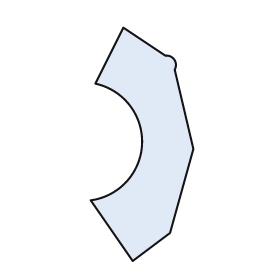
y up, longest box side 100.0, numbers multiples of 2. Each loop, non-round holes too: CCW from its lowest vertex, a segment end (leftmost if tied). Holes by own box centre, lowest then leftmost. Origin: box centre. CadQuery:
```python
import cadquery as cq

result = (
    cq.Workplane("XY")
    .moveTo(-4.0, -50.0)
    .lineTo(12.0, -38.0)
    .lineTo(22.0, -2.0)
    .lineTo(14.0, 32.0)
    .threePointArc((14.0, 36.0), (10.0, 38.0))
    .lineTo(-8.0, 50.0)
    .lineTo(-20.0, 26.0)
    .threePointArc((0.0, 0.0), (-22.0, -24.0))
    .close()
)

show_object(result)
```